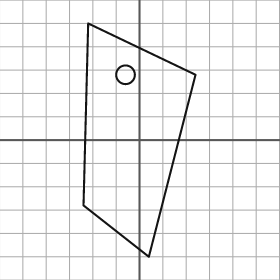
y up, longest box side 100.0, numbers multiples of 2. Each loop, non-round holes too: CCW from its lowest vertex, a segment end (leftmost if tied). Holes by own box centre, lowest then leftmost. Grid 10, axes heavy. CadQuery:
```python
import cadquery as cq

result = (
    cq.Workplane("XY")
    .moveTo(4.0, -50.0)
    .lineTo(24.0, 28.0)
    .lineTo(-22.0, 50.0)
    .lineTo(-24.0, -28.0)
    .close()
    .moveTo(-6.0, 28.0)
    .circle(4.0)
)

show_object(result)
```